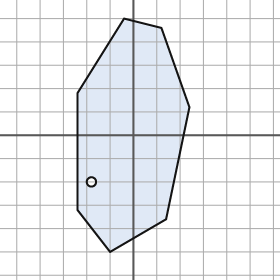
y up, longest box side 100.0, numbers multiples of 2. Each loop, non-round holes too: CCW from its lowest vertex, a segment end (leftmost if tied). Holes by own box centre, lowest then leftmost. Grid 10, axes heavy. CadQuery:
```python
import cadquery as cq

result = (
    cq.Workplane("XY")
    .moveTo(-10.0, -50.0)
    .lineTo(14.0, -36.0)
    .lineTo(24.0, 12.0)
    .lineTo(12.0, 46.0)
    .lineTo(-4.0, 50.0)
    .lineTo(-24.0, 18.0)
    .lineTo(-24.0, -32.0)
    .close()
    .moveTo(-18.0, -20.0)
    .circle(2.0)
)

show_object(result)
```